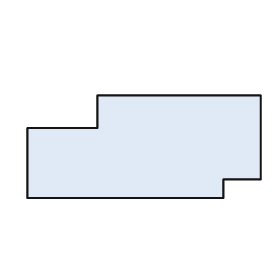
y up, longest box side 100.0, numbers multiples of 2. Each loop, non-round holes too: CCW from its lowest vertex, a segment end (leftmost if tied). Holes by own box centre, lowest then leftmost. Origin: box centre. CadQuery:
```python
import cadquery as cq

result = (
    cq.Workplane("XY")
    .moveTo(-50.0, -22.0)
    .lineTo(34.0, -22.0)
    .lineTo(34.0, -14.0)
    .lineTo(50.0, -14.0)
    .lineTo(50.0, 22.0)
    .lineTo(-20.0, 22.0)
    .lineTo(-20.0, 8.0)
    .lineTo(-50.0, 8.0)
    .close()
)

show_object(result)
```